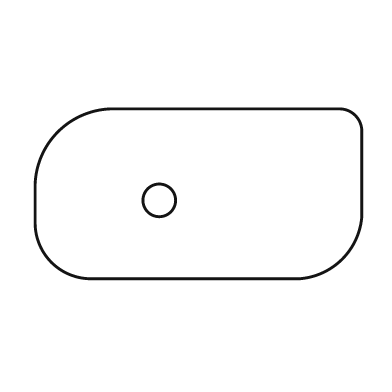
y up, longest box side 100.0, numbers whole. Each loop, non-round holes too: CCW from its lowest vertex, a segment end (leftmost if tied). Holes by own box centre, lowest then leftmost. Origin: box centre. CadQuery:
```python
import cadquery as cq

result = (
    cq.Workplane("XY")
    .moveTo(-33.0, -26.0)
    .lineTo(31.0, -26.0)
    .threePointArc((44.0, -20.0), (50.0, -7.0))
    .lineTo(50.0, 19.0)
    .threePointArc((48.0, 24.0), (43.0, 26.0))
    .lineTo(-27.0, 26.0)
    .threePointArc((-43.0, 19.0), (-50.0, 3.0))
    .lineTo(-50.0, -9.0)
    .threePointArc((-45.0, -21.0), (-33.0, -26.0))
    .close()
    .moveTo(-12.0, -2.0)
    .circle(5.0)
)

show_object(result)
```